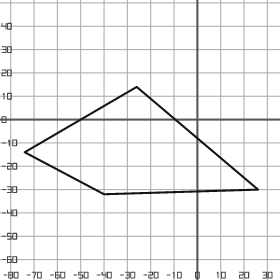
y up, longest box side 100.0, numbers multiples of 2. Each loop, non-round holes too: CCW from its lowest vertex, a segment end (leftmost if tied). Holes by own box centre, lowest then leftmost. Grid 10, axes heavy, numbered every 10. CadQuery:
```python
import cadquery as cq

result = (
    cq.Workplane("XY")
    .moveTo(-40.0, -32.0)
    .lineTo(26.0, -30.0)
    .lineTo(-26.0, 14.0)
    .lineTo(-74.0, -14.0)
    .close()
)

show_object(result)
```